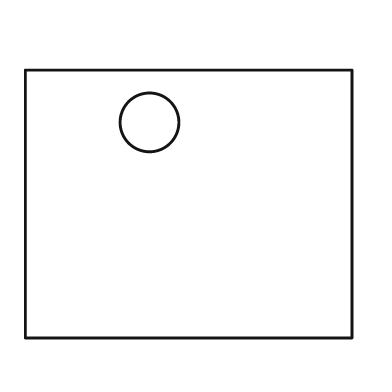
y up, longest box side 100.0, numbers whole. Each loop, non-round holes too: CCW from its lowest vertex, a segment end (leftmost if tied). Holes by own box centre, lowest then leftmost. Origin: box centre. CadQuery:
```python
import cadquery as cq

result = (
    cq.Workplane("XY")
    .moveTo(-50.0, -41.0)
    .lineTo(50.0, -41.0)
    .lineTo(50.0, 41.0)
    .lineTo(-50.0, 41.0)
    .close()
    .moveTo(-12.0, 25.0)
    .circle(9.0)
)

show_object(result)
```